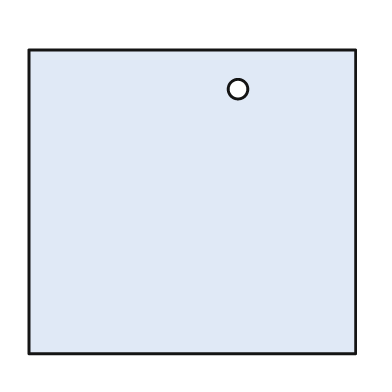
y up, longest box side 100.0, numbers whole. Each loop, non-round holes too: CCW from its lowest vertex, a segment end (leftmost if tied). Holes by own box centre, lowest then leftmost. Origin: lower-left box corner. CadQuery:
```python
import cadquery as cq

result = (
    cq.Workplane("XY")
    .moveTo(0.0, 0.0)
    .lineTo(100.0, 0.0)
    .lineTo(100.0, 93.0)
    .lineTo(0.0, 93.0)
    .close()
    .moveTo(64.0, 81.0)
    .circle(3.0)
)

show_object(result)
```